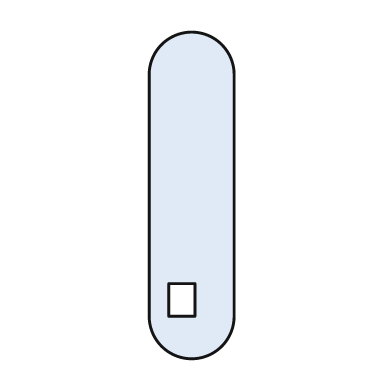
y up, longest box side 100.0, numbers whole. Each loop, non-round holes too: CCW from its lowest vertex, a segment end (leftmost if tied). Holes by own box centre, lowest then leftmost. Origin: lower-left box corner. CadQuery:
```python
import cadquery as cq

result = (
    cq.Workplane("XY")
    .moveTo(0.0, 13.0)
    .threePointArc((13.0, 0.0), (26.0, 13.0))
    .lineTo(26.0, 87.0)
    .threePointArc((13.0, 100.0), (0.0, 87.0))
    .close()
    .moveTo(6.0, 13.0)
    .lineTo(14.0, 13.0)
    .lineTo(14.0, 23.0)
    .lineTo(6.0, 23.0)
    .close()
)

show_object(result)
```